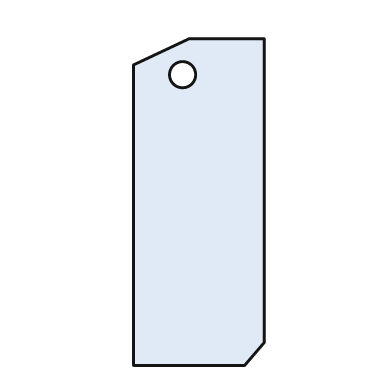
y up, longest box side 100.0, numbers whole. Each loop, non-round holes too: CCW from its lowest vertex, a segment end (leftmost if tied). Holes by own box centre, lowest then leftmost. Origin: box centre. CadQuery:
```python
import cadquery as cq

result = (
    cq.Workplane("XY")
    .moveTo(-20.0, -50.0)
    .lineTo(14.0, -50.0)
    .lineTo(20.0, -43.0)
    .lineTo(20.0, 50.0)
    .lineTo(-3.0, 50.0)
    .lineTo(-20.0, 42.0)
    .close()
    .moveTo(-5.0, 39.0)
    .circle(4.0)
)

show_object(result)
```